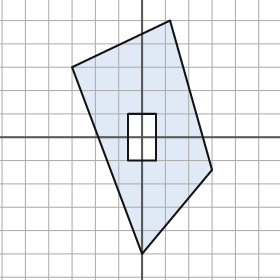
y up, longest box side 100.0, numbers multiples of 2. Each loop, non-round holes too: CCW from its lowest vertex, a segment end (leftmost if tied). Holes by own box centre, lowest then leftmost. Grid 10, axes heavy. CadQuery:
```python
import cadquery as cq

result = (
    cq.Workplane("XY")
    .moveTo(0.0, -50.0)
    .lineTo(30.0, -14.0)
    .lineTo(12.0, 50.0)
    .lineTo(-30.0, 30.0)
    .close()
    .moveTo(-6.0, -10.0)
    .lineTo(6.0, -10.0)
    .lineTo(6.0, 10.0)
    .lineTo(-6.0, 10.0)
    .close()
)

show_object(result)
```